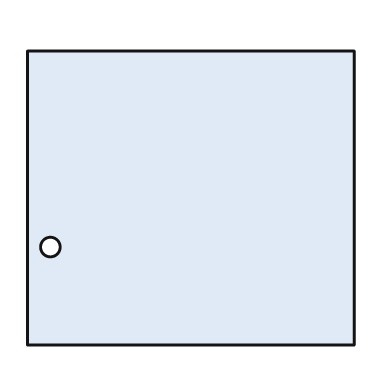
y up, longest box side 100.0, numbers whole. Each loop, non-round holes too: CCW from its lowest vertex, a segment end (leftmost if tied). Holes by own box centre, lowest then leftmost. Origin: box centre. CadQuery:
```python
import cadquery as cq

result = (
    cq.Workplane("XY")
    .moveTo(-50.0, -45.0)
    .lineTo(50.0, -45.0)
    .lineTo(50.0, 45.0)
    .lineTo(-50.0, 45.0)
    .close()
    .moveTo(-43.0, -15.0)
    .circle(3.0)
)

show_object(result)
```